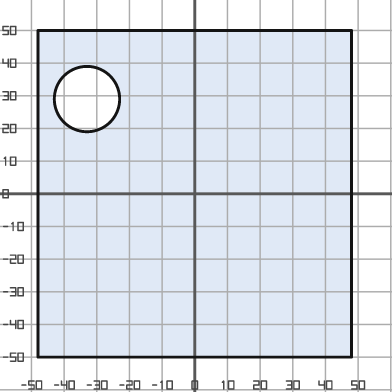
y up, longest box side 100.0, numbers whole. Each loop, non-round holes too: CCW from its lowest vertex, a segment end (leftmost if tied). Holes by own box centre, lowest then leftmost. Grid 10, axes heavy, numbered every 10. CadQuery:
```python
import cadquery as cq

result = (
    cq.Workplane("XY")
    .moveTo(-48.0, -50.0)
    .lineTo(48.0, -50.0)
    .lineTo(48.0, 50.0)
    .lineTo(-48.0, 50.0)
    .close()
    .moveTo(-33.0, 29.0)
    .circle(10.0)
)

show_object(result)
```